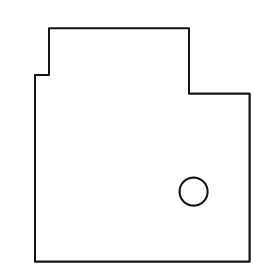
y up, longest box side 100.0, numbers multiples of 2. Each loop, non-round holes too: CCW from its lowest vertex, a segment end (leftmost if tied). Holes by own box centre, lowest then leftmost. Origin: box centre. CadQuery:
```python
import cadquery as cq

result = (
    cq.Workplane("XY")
    .moveTo(-46.0, -50.0)
    .lineTo(46.0, -50.0)
    .lineTo(46.0, 22.0)
    .lineTo(20.0, 22.0)
    .lineTo(20.0, 50.0)
    .lineTo(-40.0, 50.0)
    .lineTo(-40.0, 30.0)
    .lineTo(-46.0, 30.0)
    .close()
    .moveTo(22.0, -20.0)
    .circle(6.0)
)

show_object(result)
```